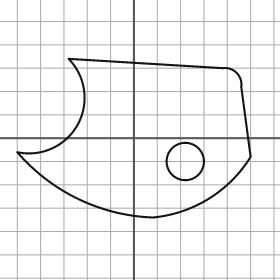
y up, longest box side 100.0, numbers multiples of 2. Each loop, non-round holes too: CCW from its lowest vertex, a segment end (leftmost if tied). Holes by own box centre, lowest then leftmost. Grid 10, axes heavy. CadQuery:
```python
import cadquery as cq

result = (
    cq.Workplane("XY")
    .moveTo(8.0, -34.0)
    .threePointArc((32.0, -26.0), (50.0, -8.0))
    .lineTo(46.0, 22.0)
    .threePointArc((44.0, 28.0), (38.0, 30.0))
    .lineTo(-28.0, 34.0)
    .threePointArc((-24.0, 6.0), (-50.0, -6.0))
    .threePointArc((-24.0, -26.0), (8.0, -34.0))
    .close()
    .moveTo(22.0, -10.0)
    .circle(8.0)
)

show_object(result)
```